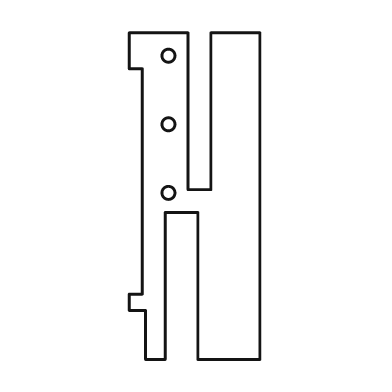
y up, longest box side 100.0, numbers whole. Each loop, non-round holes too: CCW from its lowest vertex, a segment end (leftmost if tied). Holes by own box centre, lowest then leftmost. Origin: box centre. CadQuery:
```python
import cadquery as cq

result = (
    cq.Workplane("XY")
    .moveTo(-15.0, -50.0)
    .lineTo(-9.0, -50.0)
    .lineTo(-9.0, -5.0)
    .lineTo(1.0, -5.0)
    .lineTo(1.0, -50.0)
    .lineTo(20.0, -50.0)
    .lineTo(20.0, 50.0)
    .lineTo(5.0, 50.0)
    .lineTo(5.0, 2.0)
    .lineTo(-2.0, 2.0)
    .lineTo(-2.0, 50.0)
    .lineTo(-20.0, 50.0)
    .lineTo(-20.0, 39.0)
    .lineTo(-16.0, 39.0)
    .lineTo(-16.0, -30.0)
    .lineTo(-20.0, -30.0)
    .lineTo(-20.0, -35.0)
    .lineTo(-15.0, -35.0)
    .close()
    .moveTo(-8.0, 1.0)
    .circle(2.0)
    .moveTo(-8.0, 22.0)
    .circle(2.0)
    .moveTo(-8.0, 43.0)
    .circle(2.0)
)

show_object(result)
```